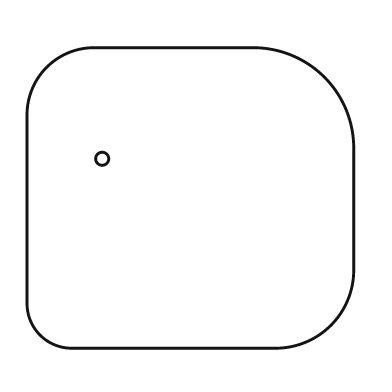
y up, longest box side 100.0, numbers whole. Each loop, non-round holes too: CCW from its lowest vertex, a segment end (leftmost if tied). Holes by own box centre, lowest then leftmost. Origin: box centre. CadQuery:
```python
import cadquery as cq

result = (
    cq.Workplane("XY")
    .moveTo(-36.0, -46.0)
    .lineTo(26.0, -46.0)
    .threePointArc((43.0, -39.0), (50.0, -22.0))
    .lineTo(50.0, 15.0)
    .threePointArc((41.0, 37.0), (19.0, 46.0))
    .lineTo(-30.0, 46.0)
    .threePointArc((-44.0, 40.0), (-50.0, 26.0))
    .lineTo(-50.0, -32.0)
    .threePointArc((-46.0, -42.0), (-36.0, -46.0))
    .close()
    .moveTo(-27.0, 12.0)
    .circle(2.0)
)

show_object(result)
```